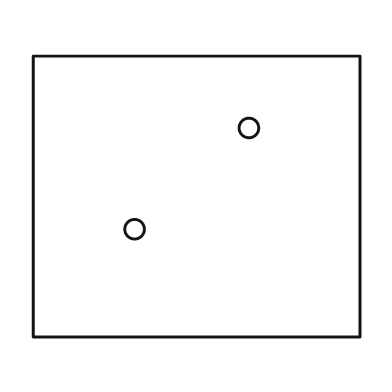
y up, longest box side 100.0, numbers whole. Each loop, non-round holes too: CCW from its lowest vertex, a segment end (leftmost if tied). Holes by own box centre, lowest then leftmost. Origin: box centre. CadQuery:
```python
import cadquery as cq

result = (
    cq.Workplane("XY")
    .moveTo(-50.0, -43.0)
    .lineTo(50.0, -43.0)
    .lineTo(50.0, 43.0)
    .lineTo(-50.0, 43.0)
    .close()
    .moveTo(-19.0, -10.0)
    .circle(3.0)
    .moveTo(16.0, 21.0)
    .circle(3.0)
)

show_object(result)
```